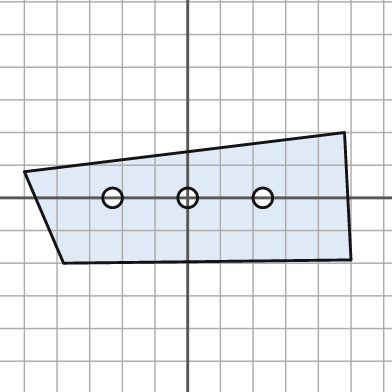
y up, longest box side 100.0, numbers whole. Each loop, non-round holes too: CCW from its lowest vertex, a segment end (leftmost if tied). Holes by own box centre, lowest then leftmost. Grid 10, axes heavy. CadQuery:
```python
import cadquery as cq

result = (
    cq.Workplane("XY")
    .moveTo(-38.0, -20.0)
    .lineTo(50.0, -19.0)
    .lineTo(48.0, 20.0)
    .lineTo(-50.0, 8.0)
    .close()
    .moveTo(-23.0, 0.0)
    .circle(3.0)
    .moveTo(0.0, 0.0)
    .circle(3.0)
    .moveTo(23.0, 0.0)
    .circle(3.0)
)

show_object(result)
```